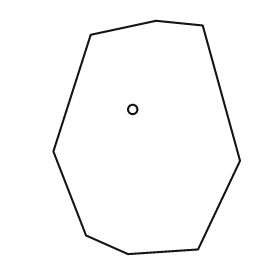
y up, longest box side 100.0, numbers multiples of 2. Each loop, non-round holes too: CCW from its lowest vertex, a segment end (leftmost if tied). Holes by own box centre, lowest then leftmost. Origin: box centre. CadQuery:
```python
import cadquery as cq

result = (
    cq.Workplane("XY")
    .moveTo(-8.0, -50.0)
    .lineTo(22.0, -48.0)
    .lineTo(40.0, -10.0)
    .lineTo(24.0, 48.0)
    .lineTo(4.0, 50.0)
    .lineTo(-24.0, 44.0)
    .lineTo(-40.0, -6.0)
    .lineTo(-26.0, -42.0)
    .close()
    .moveTo(-6.0, 12.0)
    .circle(2.0)
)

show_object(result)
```